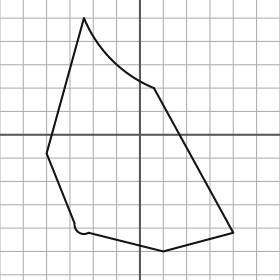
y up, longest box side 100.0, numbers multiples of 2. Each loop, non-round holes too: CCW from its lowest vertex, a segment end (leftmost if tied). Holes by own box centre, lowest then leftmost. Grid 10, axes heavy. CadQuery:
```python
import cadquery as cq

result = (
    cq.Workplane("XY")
    .moveTo(10.0, -50.0)
    .lineTo(40.0, -42.0)
    .lineTo(6.0, 20.0)
    .threePointArc((-12.0, 32.0), (-24.0, 50.0))
    .lineTo(-40.0, -8.0)
    .lineTo(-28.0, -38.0)
    .threePointArc((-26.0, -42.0), (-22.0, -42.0))
    .close()
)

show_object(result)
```